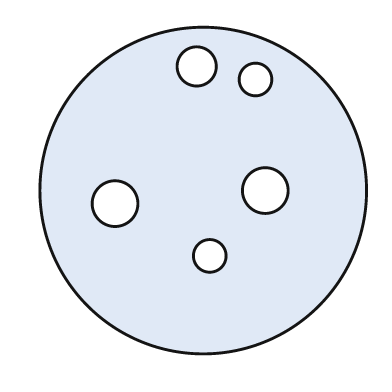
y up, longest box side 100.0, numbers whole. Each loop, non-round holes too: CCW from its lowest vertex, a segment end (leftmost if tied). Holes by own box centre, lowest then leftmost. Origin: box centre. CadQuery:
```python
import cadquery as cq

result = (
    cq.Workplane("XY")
    .moveTo(0.0, 0.0)
    .circle(50.0)
    .moveTo(2.0, -20.0)
    .circle(5.0)
    .moveTo(-27.0, -4.0)
    .circle(7.0)
    .moveTo(19.0, 0.0)
    .circle(7.0)
    .moveTo(16.0, 34.0)
    .circle(5.0)
    .moveTo(-2.0, 38.0)
    .circle(6.0)
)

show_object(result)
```